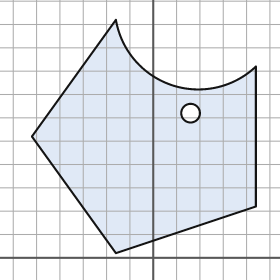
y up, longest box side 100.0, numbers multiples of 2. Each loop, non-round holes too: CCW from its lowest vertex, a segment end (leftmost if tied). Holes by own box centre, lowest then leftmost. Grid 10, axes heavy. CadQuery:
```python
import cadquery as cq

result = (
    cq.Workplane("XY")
    .moveTo(-16.0, 2.0)
    .lineTo(44.0, 22.0)
    .lineTo(44.0, 82.0)
    .threePointArc((8.0, 74.0), (-16.0, 102.0))
    .lineTo(-52.0, 52.0)
    .close()
    .moveTo(16.0, 62.0)
    .circle(4.0)
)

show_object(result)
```